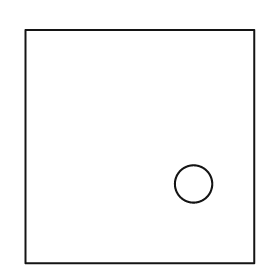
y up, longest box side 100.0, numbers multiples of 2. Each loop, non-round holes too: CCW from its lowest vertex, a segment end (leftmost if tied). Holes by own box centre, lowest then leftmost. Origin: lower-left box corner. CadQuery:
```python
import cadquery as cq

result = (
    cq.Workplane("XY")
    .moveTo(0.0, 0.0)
    .lineTo(98.0, 0.0)
    .lineTo(98.0, 100.0)
    .lineTo(0.0, 100.0)
    .close()
    .moveTo(72.0, 34.0)
    .circle(8.0)
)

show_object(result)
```